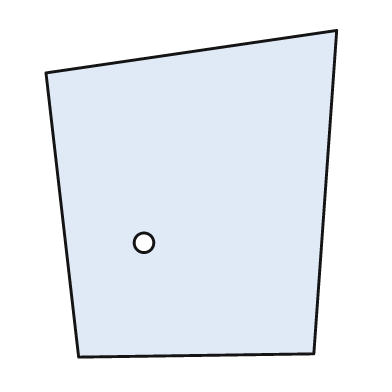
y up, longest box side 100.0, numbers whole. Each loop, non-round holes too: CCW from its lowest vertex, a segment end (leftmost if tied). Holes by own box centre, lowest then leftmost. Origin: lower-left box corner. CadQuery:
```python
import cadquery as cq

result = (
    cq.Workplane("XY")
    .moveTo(10.0, 0.0)
    .lineTo(82.0, 1.0)
    .lineTo(89.0, 100.0)
    .lineTo(0.0, 87.0)
    .close()
    .moveTo(30.0, 35.0)
    .circle(3.0)
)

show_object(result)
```